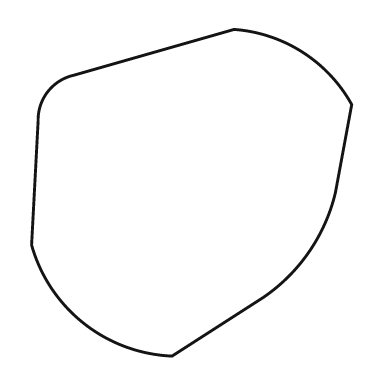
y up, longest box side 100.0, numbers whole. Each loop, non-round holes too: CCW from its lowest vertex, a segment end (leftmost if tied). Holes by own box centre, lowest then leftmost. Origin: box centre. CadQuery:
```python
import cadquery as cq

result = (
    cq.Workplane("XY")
    .moveTo(-6.0, -50.0)
    .lineTo(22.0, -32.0)
    .threePointArc((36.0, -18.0), (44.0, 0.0))
    .lineTo(49.0, 27.0)
    .threePointArc((34.0, 43.0), (13.0, 50.0))
    .lineTo(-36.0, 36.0)
    .threePointArc((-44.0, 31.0), (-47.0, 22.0))
    .lineTo(-49.0, -16.0)
    .threePointArc((-33.0, -40.0), (-6.0, -50.0))
    .close()
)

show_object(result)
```